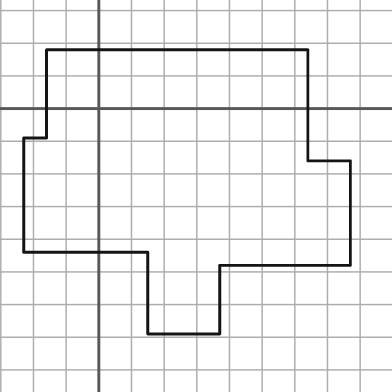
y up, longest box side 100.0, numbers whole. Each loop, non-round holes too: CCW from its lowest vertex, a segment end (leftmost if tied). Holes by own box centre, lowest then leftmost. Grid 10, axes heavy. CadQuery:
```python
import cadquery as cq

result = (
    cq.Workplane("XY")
    .moveTo(15.0, -69.0)
    .lineTo(37.0, -69.0)
    .lineTo(37.0, -48.0)
    .lineTo(77.0, -48.0)
    .lineTo(77.0, -16.0)
    .lineTo(64.0, -16.0)
    .lineTo(64.0, 18.0)
    .lineTo(-16.0, 18.0)
    .lineTo(-16.0, -9.0)
    .lineTo(-23.0, -9.0)
    .lineTo(-23.0, -44.0)
    .lineTo(15.0, -44.0)
    .close()
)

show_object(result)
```